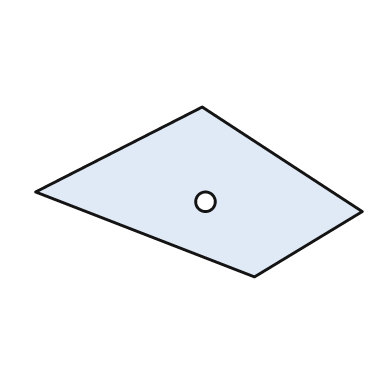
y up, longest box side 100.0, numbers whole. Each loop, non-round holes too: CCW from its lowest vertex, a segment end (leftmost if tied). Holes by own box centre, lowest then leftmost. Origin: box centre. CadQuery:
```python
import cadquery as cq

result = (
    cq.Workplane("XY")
    .moveTo(17.0, -26.0)
    .lineTo(50.0, -6.0)
    .lineTo(1.0, 26.0)
    .lineTo(-50.0, 0.0)
    .close()
    .moveTo(2.0, -3.0)
    .circle(3.0)
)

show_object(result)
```